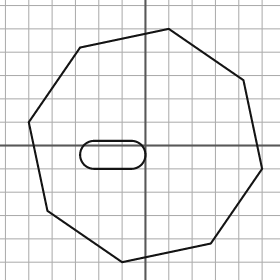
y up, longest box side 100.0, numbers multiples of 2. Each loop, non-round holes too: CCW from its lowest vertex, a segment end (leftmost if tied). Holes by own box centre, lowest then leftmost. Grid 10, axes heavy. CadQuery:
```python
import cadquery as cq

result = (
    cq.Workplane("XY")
    .moveTo(-10.0, -50.0)
    .lineTo(28.0, -42.0)
    .lineTo(50.0, -10.0)
    .lineTo(42.0, 28.0)
    .lineTo(10.0, 50.0)
    .lineTo(-28.0, 42.0)
    .lineTo(-50.0, 10.0)
    .lineTo(-42.0, -28.0)
    .close()
    .moveTo(-22.0, -10.0)
    .lineTo(-6.0, -10.0)
    .threePointArc((0.0, -4.0), (-6.0, 2.0))
    .lineTo(-22.0, 2.0)
    .threePointArc((-28.0, -4.0), (-22.0, -10.0))
    .close()
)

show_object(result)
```